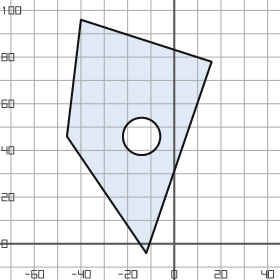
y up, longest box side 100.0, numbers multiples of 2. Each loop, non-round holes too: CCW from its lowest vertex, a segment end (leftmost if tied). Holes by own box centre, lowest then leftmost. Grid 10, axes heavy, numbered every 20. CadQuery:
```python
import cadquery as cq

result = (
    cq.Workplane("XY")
    .moveTo(-12.0, -4.0)
    .lineTo(16.0, 78.0)
    .lineTo(-40.0, 96.0)
    .lineTo(-46.0, 46.0)
    .close()
    .moveTo(-14.0, 46.0)
    .circle(8.0)
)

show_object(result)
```